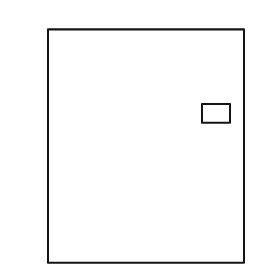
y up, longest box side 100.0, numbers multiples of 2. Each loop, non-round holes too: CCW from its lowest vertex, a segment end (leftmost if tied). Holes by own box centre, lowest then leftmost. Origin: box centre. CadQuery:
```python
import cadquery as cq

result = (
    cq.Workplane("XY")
    .moveTo(-42.0, -50.0)
    .lineTo(42.0, -50.0)
    .lineTo(42.0, 50.0)
    .lineTo(-42.0, 50.0)
    .close()
    .moveTo(24.0, 10.0)
    .lineTo(36.0, 10.0)
    .lineTo(36.0, 18.0)
    .lineTo(24.0, 18.0)
    .close()
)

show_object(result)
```